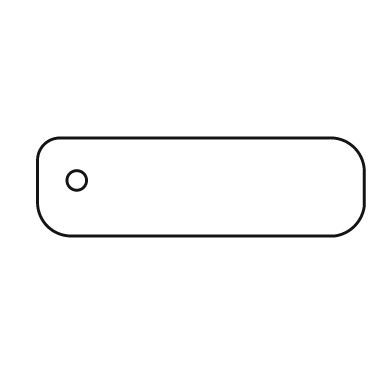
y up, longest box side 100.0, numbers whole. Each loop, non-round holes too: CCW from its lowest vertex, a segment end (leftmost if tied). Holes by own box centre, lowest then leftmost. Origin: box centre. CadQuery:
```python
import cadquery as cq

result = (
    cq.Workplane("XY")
    .moveTo(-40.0, -15.0)
    .lineTo(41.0, -15.0)
    .threePointArc((47.0, -12.0), (50.0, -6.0))
    .lineTo(50.0, 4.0)
    .threePointArc((47.0, 12.0), (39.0, 15.0))
    .lineTo(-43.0, 15.0)
    .threePointArc((-48.0, 13.0), (-50.0, 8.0))
    .lineTo(-50.0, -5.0)
    .threePointArc((-47.0, -12.0), (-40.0, -15.0))
    .close()
    .moveTo(-38.0, 2.0)
    .circle(3.0)
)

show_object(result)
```